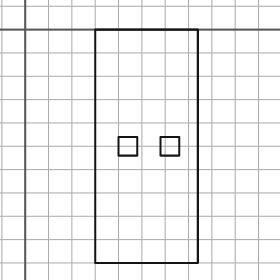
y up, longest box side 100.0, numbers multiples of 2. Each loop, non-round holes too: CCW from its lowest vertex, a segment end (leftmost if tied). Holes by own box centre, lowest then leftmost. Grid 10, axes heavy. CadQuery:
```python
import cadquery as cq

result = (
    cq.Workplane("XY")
    .moveTo(30.0, -100.0)
    .lineTo(74.0, -100.0)
    .lineTo(74.0, 0.0)
    .lineTo(30.0, 0.0)
    .close()
    .moveTo(40.0, -54.0)
    .lineTo(48.0, -54.0)
    .lineTo(48.0, -46.0)
    .lineTo(40.0, -46.0)
    .close()
    .moveTo(58.0, -54.0)
    .lineTo(66.0, -54.0)
    .lineTo(66.0, -46.0)
    .lineTo(58.0, -46.0)
    .close()
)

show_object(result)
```